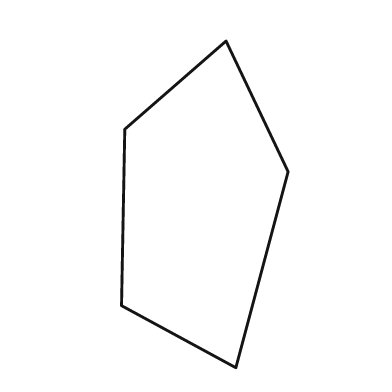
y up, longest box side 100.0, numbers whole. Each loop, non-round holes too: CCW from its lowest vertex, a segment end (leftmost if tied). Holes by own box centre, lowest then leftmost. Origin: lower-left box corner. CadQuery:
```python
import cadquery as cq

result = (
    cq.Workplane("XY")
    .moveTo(35.0, 0.0)
    .lineTo(51.0, 60.0)
    .lineTo(32.0, 100.0)
    .lineTo(1.0, 73.0)
    .lineTo(0.0, 19.0)
    .close()
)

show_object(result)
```